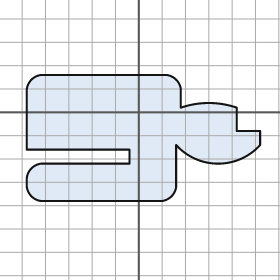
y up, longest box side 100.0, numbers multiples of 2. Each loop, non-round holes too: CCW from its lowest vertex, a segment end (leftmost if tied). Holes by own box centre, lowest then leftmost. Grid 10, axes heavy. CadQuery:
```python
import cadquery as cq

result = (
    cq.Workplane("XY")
    .moveTo(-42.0, -38.0)
    .lineTo(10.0, -38.0)
    .threePointArc((14.0, -36.0), (16.0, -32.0))
    .lineTo(16.0, -14.0)
    .threePointArc((34.0, -22.0), (52.0, -14.0))
    .lineTo(52.0, -8.0)
    .lineTo(42.0, -8.0)
    .lineTo(42.0, 2.0)
    .threePointArc((30.0, 4.0), (18.0, 2.0))
    .lineTo(18.0, 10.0)
    .threePointArc((16.0, 14.0), (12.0, 16.0))
    .lineTo(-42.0, 16.0)
    .threePointArc((-46.0, 14.0), (-48.0, 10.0))
    .lineTo(-48.0, -16.0)
    .lineTo(-4.0, -16.0)
    .lineTo(-4.0, -22.0)
    .lineTo(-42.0, -22.0)
    .threePointArc((-46.0, -24.0), (-48.0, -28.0))
    .lineTo(-48.0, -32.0)
    .threePointArc((-46.0, -36.0), (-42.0, -38.0))
    .close()
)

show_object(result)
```